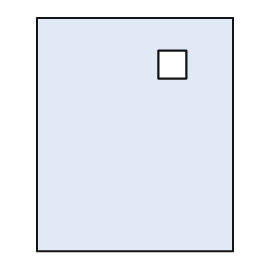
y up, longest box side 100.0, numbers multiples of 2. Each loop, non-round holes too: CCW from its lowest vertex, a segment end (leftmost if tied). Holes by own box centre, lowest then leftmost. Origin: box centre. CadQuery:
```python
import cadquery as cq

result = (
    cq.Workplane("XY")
    .moveTo(-42.0, -50.0)
    .lineTo(42.0, -50.0)
    .lineTo(42.0, 50.0)
    .lineTo(-42.0, 50.0)
    .close()
    .moveTo(10.0, 24.0)
    .lineTo(22.0, 24.0)
    .lineTo(22.0, 36.0)
    .lineTo(10.0, 36.0)
    .close()
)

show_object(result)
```